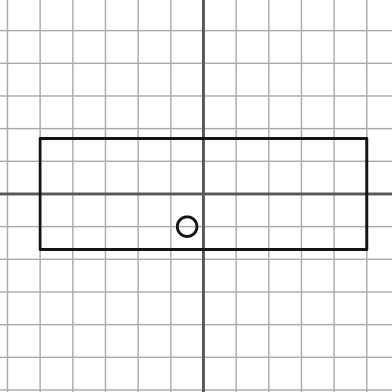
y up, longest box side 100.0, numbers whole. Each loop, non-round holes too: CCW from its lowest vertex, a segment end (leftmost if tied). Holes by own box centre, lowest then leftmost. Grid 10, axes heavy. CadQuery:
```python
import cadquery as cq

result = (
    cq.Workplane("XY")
    .moveTo(-50.0, -17.0)
    .lineTo(50.0, -17.0)
    .lineTo(50.0, 17.0)
    .lineTo(-50.0, 17.0)
    .close()
    .moveTo(-5.0, -10.0)
    .circle(3.0)
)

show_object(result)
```